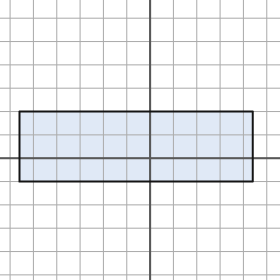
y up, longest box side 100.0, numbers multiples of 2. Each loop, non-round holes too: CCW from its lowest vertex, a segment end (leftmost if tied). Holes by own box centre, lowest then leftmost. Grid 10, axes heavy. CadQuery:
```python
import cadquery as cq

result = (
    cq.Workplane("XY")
    .moveTo(-56.0, -10.0)
    .lineTo(44.0, -10.0)
    .lineTo(44.0, 20.0)
    .lineTo(-56.0, 20.0)
    .close()
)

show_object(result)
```